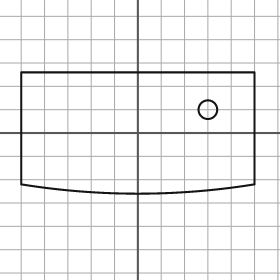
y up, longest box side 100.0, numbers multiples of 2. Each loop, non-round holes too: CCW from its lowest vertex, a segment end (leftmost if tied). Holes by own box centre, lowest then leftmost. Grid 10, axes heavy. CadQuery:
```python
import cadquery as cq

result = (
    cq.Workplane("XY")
    .moveTo(-50.0, -22.0)
    .threePointArc((0.0, -26.0), (50.0, -22.0))
    .lineTo(50.0, 26.0)
    .lineTo(-50.0, 26.0)
    .close()
    .moveTo(30.0, 10.0)
    .circle(4.0)
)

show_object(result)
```